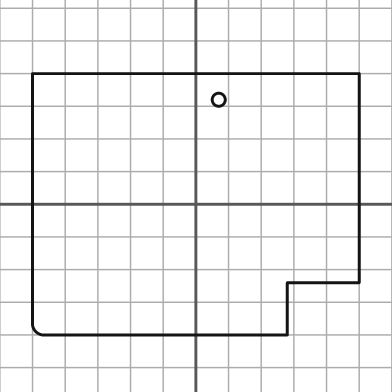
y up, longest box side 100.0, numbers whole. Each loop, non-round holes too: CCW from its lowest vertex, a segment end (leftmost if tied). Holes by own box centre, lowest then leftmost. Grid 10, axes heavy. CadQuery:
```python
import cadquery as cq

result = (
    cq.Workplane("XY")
    .moveTo(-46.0, -40.0)
    .lineTo(28.0, -40.0)
    .lineTo(28.0, -24.0)
    .lineTo(50.0, -24.0)
    .lineTo(50.0, 40.0)
    .lineTo(-50.0, 40.0)
    .lineTo(-50.0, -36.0)
    .threePointArc((-49.0, -39.0), (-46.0, -40.0))
    .close()
    .moveTo(7.0, 32.0)
    .circle(2.0)
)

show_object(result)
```